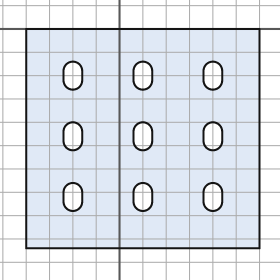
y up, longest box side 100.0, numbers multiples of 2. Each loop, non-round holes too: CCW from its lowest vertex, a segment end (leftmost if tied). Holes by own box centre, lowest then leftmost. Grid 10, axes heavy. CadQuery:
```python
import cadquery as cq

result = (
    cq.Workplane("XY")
    .moveTo(-40.0, -94.0)
    .lineTo(60.0, -94.0)
    .lineTo(60.0, 0.0)
    .lineTo(-40.0, 0.0)
    .close()
    .moveTo(-24.0, -74.0)
    .threePointArc((-20.0, -78.0), (-16.0, -74.0))
    .lineTo(-16.0, -70.0)
    .threePointArc((-20.0, -66.0), (-24.0, -70.0))
    .close()
    .moveTo(6.0, -74.0)
    .threePointArc((10.0, -78.0), (14.0, -74.0))
    .lineTo(14.0, -70.0)
    .threePointArc((10.0, -66.0), (6.0, -70.0))
    .close()
    .moveTo(36.0, -74.0)
    .threePointArc((40.0, -78.0), (44.0, -74.0))
    .lineTo(44.0, -70.0)
    .threePointArc((40.0, -66.0), (36.0, -70.0))
    .close()
    .moveTo(-24.0, -48.0)
    .threePointArc((-20.0, -52.0), (-16.0, -48.0))
    .lineTo(-16.0, -44.0)
    .threePointArc((-20.0, -40.0), (-24.0, -44.0))
    .close()
    .moveTo(6.0, -48.0)
    .threePointArc((10.0, -52.0), (14.0, -48.0))
    .lineTo(14.0, -44.0)
    .threePointArc((10.0, -40.0), (6.0, -44.0))
    .close()
    .moveTo(36.0, -48.0)
    .threePointArc((40.0, -52.0), (44.0, -48.0))
    .lineTo(44.0, -44.0)
    .threePointArc((40.0, -40.0), (36.0, -44.0))
    .close()
    .moveTo(-24.0, -22.0)
    .threePointArc((-20.0, -26.0), (-16.0, -22.0))
    .lineTo(-16.0, -18.0)
    .threePointArc((-20.0, -14.0), (-24.0, -18.0))
    .close()
    .moveTo(6.0, -22.0)
    .threePointArc((10.0, -26.0), (14.0, -22.0))
    .lineTo(14.0, -18.0)
    .threePointArc((10.0, -14.0), (6.0, -18.0))
    .close()
    .moveTo(36.0, -22.0)
    .threePointArc((40.0, -26.0), (44.0, -22.0))
    .lineTo(44.0, -18.0)
    .threePointArc((40.0, -14.0), (36.0, -18.0))
    .close()
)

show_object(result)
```